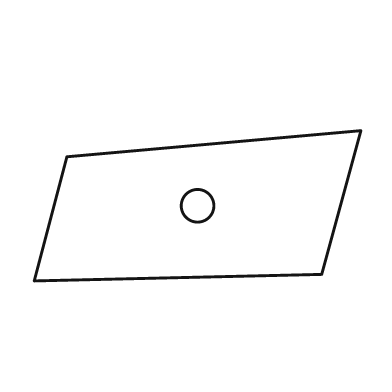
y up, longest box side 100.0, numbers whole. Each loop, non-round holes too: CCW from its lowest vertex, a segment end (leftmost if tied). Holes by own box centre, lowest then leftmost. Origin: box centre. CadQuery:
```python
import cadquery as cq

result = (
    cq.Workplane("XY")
    .moveTo(-50.0, -23.0)
    .lineTo(38.0, -21.0)
    .lineTo(50.0, 23.0)
    .lineTo(-40.0, 15.0)
    .close()
    .moveTo(0.0, 0.0)
    .circle(5.0)
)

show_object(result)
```